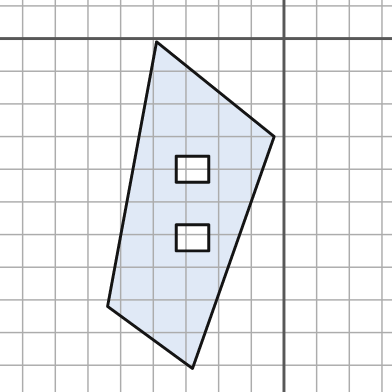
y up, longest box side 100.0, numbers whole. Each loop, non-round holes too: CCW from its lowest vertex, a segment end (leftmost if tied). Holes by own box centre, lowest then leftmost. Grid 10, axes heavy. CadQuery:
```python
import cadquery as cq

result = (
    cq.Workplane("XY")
    .moveTo(-28.0, -101.0)
    .lineTo(-3.0, -30.0)
    .lineTo(-39.0, -1.0)
    .lineTo(-54.0, -82.0)
    .close()
    .moveTo(-33.0, -65.0)
    .lineTo(-23.0, -65.0)
    .lineTo(-23.0, -57.0)
    .lineTo(-33.0, -57.0)
    .close()
    .moveTo(-33.0, -44.0)
    .lineTo(-23.0, -44.0)
    .lineTo(-23.0, -36.0)
    .lineTo(-33.0, -36.0)
    .close()
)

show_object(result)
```